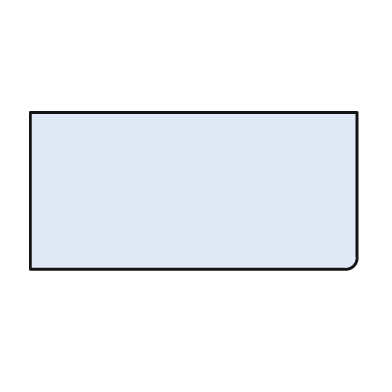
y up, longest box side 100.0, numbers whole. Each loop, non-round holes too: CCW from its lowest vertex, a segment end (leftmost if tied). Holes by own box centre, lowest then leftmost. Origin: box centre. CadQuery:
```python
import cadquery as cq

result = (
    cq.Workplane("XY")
    .moveTo(-50.0, -24.0)
    .lineTo(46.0, -24.0)
    .threePointArc((49.0, -23.0), (50.0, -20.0))
    .lineTo(50.0, 24.0)
    .lineTo(-50.0, 24.0)
    .close()
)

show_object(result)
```